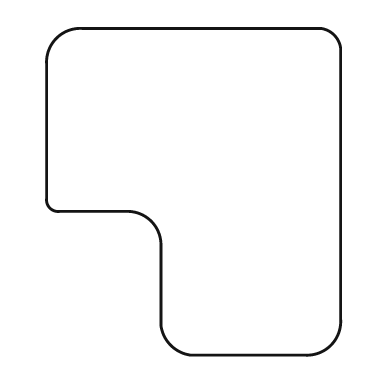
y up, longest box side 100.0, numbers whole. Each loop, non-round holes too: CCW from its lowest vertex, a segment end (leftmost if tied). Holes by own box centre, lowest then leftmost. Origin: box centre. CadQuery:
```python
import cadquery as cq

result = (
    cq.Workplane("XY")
    .moveTo(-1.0, -50.0)
    .lineTo(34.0, -50.0)
    .threePointArc((42.0, -47.0), (45.0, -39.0))
    .lineTo(45.0, 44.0)
    .threePointArc((43.0, 48.0), (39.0, 50.0))
    .lineTo(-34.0, 50.0)
    .threePointArc((-42.0, 47.0), (-45.0, 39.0))
    .lineTo(-45.0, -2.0)
    .threePointArc((-44.0, -5.0), (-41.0, -6.0))
    .lineTo(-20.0, -6.0)
    .threePointArc((-13.0, -9.0), (-10.0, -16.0))
    .lineTo(-10.0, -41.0)
    .threePointArc((-7.0, -47.0), (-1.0, -50.0))
    .close()
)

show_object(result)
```